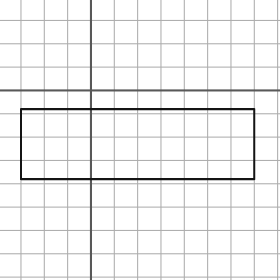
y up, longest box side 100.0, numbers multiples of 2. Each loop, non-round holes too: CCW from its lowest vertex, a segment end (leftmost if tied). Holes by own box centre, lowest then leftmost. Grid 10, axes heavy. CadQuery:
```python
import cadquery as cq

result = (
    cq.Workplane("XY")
    .moveTo(-30.0, -38.0)
    .lineTo(70.0, -38.0)
    .lineTo(70.0, -8.0)
    .lineTo(-30.0, -8.0)
    .close()
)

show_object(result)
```